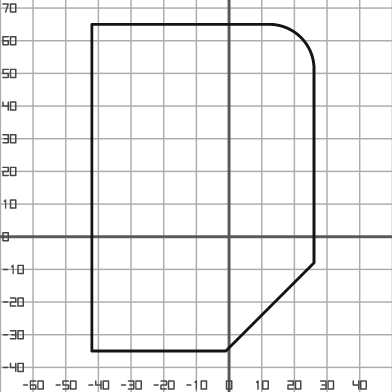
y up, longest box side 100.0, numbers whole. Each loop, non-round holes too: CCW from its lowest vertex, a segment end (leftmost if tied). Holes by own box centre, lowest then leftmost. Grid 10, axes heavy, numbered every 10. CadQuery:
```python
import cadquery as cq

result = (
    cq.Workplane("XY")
    .moveTo(-42.0, -35.0)
    .lineTo(-1.0, -35.0)
    .lineTo(26.0, -8.0)
    .lineTo(26.0, 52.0)
    .threePointArc((22.0, 61.0), (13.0, 65.0))
    .lineTo(-42.0, 65.0)
    .close()
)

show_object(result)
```